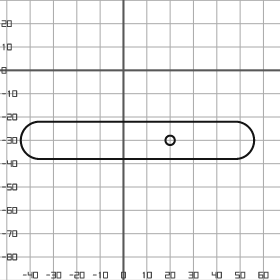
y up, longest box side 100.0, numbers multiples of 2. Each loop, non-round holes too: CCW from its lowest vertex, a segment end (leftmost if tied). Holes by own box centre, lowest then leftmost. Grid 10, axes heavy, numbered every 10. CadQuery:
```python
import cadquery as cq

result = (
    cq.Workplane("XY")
    .moveTo(-36.0, -38.0)
    .lineTo(48.0, -38.0)
    .threePointArc((56.0, -30.0), (48.0, -22.0))
    .lineTo(-36.0, -22.0)
    .threePointArc((-44.0, -30.0), (-36.0, -38.0))
    .close()
    .moveTo(20.0, -30.0)
    .circle(2.0)
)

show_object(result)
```